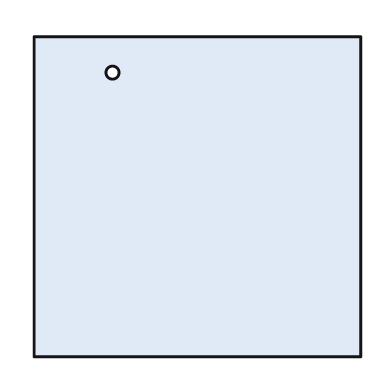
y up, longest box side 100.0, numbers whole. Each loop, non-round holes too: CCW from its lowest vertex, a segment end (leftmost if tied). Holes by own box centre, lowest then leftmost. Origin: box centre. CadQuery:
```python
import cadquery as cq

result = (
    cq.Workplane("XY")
    .moveTo(-50.0, -49.0)
    .lineTo(50.0, -49.0)
    .lineTo(50.0, 49.0)
    .lineTo(-50.0, 49.0)
    .close()
    .moveTo(-26.0, 38.0)
    .circle(2.0)
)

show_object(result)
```